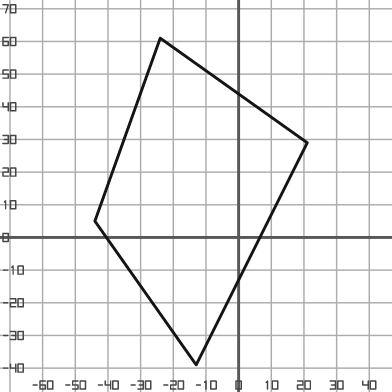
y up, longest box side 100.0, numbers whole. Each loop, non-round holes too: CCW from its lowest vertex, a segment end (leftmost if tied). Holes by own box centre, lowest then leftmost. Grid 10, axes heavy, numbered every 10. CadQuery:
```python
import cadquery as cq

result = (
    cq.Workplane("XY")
    .moveTo(-13.0, -39.0)
    .lineTo(21.0, 29.0)
    .lineTo(-24.0, 61.0)
    .lineTo(-44.0, 5.0)
    .close()
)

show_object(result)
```